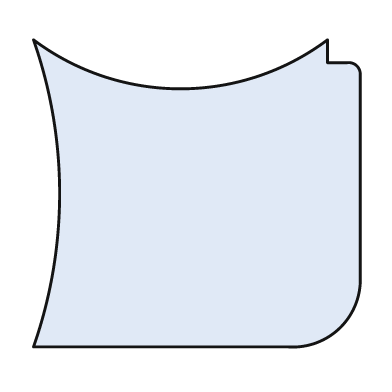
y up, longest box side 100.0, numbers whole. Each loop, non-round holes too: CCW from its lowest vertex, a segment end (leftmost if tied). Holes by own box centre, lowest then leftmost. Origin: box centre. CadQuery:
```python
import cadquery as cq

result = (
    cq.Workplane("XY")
    .moveTo(-50.0, -47.0)
    .lineTo(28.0, -47.0)
    .threePointArc((44.0, -41.0), (50.0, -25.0))
    .lineTo(50.0, 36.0)
    .threePointArc((49.0, 39.0), (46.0, 40.0))
    .lineTo(40.0, 40.0)
    .lineTo(40.0, 47.0)
    .threePointArc((-5.0, 32.0), (-50.0, 47.0))
    .threePointArc((-42.0, 0.0), (-50.0, -47.0))
    .close()
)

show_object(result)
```